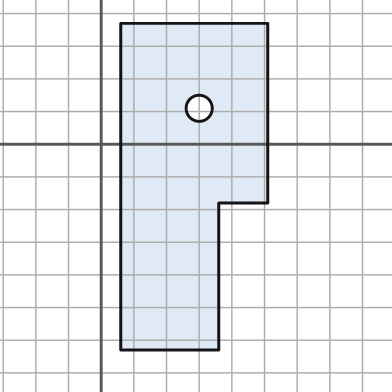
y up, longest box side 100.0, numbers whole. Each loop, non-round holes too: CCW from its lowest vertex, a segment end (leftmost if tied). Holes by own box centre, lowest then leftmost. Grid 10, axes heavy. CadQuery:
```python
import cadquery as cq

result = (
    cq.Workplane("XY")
    .moveTo(6.0, -63.0)
    .lineTo(36.0, -63.0)
    .lineTo(36.0, -18.0)
    .lineTo(51.0, -18.0)
    .lineTo(51.0, 37.0)
    .lineTo(6.0, 37.0)
    .close()
    .moveTo(30.0, 11.0)
    .circle(4.0)
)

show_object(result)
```